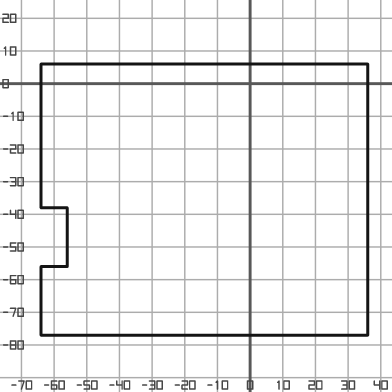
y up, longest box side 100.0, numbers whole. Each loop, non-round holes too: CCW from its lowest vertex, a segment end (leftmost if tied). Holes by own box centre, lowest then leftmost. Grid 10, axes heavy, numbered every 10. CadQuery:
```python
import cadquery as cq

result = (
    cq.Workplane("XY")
    .moveTo(-64.0, -77.0)
    .lineTo(36.0, -77.0)
    .lineTo(36.0, 6.0)
    .lineTo(-64.0, 6.0)
    .lineTo(-64.0, -38.0)
    .lineTo(-56.0, -38.0)
    .lineTo(-56.0, -56.0)
    .lineTo(-64.0, -56.0)
    .close()
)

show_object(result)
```